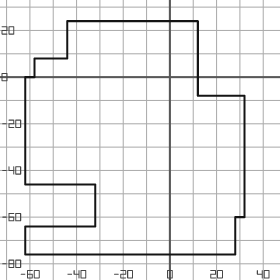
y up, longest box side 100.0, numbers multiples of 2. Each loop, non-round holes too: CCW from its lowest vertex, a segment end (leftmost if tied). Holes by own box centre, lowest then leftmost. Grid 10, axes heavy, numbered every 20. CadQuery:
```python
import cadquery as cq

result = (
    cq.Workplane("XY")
    .moveTo(-62.0, -76.0)
    .lineTo(28.0, -76.0)
    .lineTo(28.0, -60.0)
    .lineTo(32.0, -60.0)
    .lineTo(32.0, -8.0)
    .lineTo(12.0, -8.0)
    .lineTo(12.0, 24.0)
    .lineTo(-44.0, 24.0)
    .lineTo(-44.0, 8.0)
    .lineTo(-58.0, 8.0)
    .lineTo(-58.0, 0.0)
    .lineTo(-62.0, 0.0)
    .lineTo(-62.0, -46.0)
    .lineTo(-32.0, -46.0)
    .lineTo(-32.0, -64.0)
    .lineTo(-62.0, -64.0)
    .close()
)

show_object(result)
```